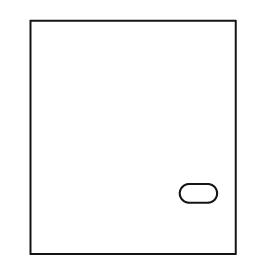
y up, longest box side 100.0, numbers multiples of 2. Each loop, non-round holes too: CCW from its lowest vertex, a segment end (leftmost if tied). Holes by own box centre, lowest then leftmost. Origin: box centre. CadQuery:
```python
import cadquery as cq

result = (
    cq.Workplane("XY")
    .moveTo(-44.0, -50.0)
    .lineTo(44.0, -50.0)
    .lineTo(44.0, 50.0)
    .lineTo(-44.0, 50.0)
    .close()
    .moveTo(24.0, -28.0)
    .lineTo(32.0, -28.0)
    .threePointArc((36.0, -24.0), (32.0, -20.0))
    .lineTo(24.0, -20.0)
    .threePointArc((20.0, -24.0), (24.0, -28.0))
    .close()
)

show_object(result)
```